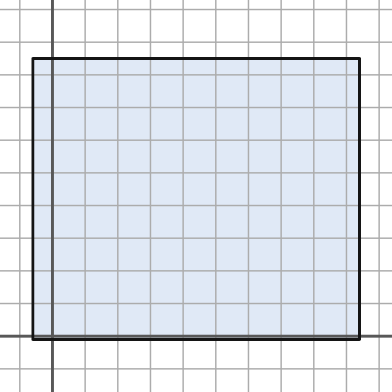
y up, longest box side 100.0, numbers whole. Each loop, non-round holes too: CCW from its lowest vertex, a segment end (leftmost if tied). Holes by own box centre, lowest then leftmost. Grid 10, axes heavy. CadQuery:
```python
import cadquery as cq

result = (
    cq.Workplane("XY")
    .moveTo(-6.0, -1.0)
    .lineTo(94.0, -1.0)
    .lineTo(94.0, 85.0)
    .lineTo(-6.0, 85.0)
    .close()
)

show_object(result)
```